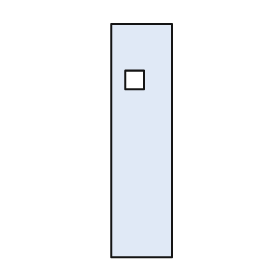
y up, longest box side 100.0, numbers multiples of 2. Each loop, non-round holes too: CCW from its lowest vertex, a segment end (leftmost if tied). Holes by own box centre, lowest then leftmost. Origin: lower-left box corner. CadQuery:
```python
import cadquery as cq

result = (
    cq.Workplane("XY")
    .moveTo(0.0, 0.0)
    .lineTo(26.0, 0.0)
    .lineTo(26.0, 100.0)
    .lineTo(0.0, 100.0)
    .close()
    .moveTo(6.0, 72.0)
    .lineTo(14.0, 72.0)
    .lineTo(14.0, 80.0)
    .lineTo(6.0, 80.0)
    .close()
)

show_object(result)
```